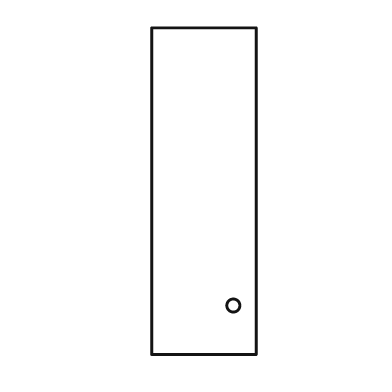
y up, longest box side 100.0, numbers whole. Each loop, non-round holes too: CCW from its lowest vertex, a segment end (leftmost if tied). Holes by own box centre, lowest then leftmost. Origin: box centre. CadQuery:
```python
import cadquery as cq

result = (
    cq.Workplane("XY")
    .moveTo(-16.0, -50.0)
    .lineTo(16.0, -50.0)
    .lineTo(16.0, 50.0)
    .lineTo(-16.0, 50.0)
    .close()
    .moveTo(9.0, -35.0)
    .circle(2.0)
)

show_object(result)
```